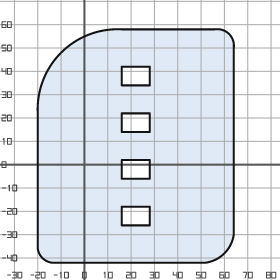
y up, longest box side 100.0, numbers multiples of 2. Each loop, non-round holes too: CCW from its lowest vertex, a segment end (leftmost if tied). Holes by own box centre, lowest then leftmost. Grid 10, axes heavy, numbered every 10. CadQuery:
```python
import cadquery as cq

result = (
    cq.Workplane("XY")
    .moveTo(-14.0, -42.0)
    .lineTo(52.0, -42.0)
    .threePointArc((60.0, -38.0), (64.0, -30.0))
    .lineTo(64.0, 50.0)
    .threePointArc((62.0, 56.0), (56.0, 58.0))
    .lineTo(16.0, 58.0)
    .threePointArc((-10.0, 48.0), (-20.0, 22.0))
    .lineTo(-20.0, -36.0)
    .threePointArc((-18.0, -40.0), (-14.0, -42.0))
    .close()
    .moveTo(16.0, -26.0)
    .lineTo(28.0, -26.0)
    .lineTo(28.0, -18.0)
    .lineTo(16.0, -18.0)
    .close()
    .moveTo(16.0, -6.0)
    .lineTo(28.0, -6.0)
    .lineTo(28.0, 2.0)
    .lineTo(16.0, 2.0)
    .close()
    .moveTo(16.0, 14.0)
    .lineTo(28.0, 14.0)
    .lineTo(28.0, 22.0)
    .lineTo(16.0, 22.0)
    .close()
    .moveTo(16.0, 34.0)
    .lineTo(28.0, 34.0)
    .lineTo(28.0, 42.0)
    .lineTo(16.0, 42.0)
    .close()
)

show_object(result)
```